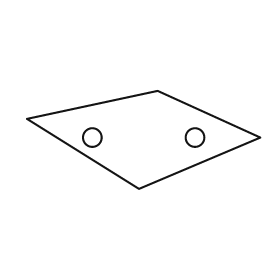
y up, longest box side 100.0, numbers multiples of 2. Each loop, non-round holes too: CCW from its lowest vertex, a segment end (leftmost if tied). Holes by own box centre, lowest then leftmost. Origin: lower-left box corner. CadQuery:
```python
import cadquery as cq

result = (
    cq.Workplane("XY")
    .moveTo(48.0, 0.0)
    .lineTo(100.0, 22.0)
    .lineTo(56.0, 42.0)
    .lineTo(0.0, 30.0)
    .close()
    .moveTo(28.0, 22.0)
    .circle(4.0)
    .moveTo(72.0, 22.0)
    .circle(4.0)
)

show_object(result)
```